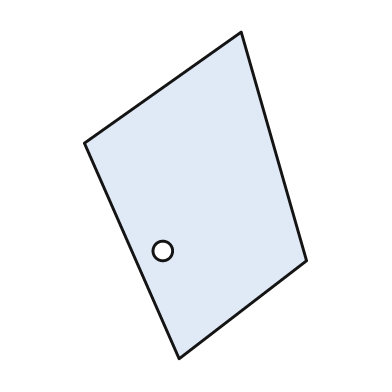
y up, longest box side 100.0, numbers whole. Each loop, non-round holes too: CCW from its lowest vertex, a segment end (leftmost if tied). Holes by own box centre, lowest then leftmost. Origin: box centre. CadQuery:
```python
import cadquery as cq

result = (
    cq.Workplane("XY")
    .moveTo(-5.0, -50.0)
    .lineTo(34.0, -20.0)
    .lineTo(14.0, 50.0)
    .lineTo(-34.0, 16.0)
    .close()
    .moveTo(-10.0, -17.0)
    .circle(3.0)
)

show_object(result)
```